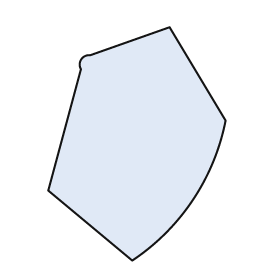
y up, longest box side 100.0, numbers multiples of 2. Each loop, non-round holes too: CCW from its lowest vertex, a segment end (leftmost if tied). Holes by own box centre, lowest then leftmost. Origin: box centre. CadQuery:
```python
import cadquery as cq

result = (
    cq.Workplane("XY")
    .moveTo(-2.0, -50.0)
    .threePointArc((24.0, -24.0), (38.0, 10.0))
    .lineTo(14.0, 50.0)
    .lineTo(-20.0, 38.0)
    .threePointArc((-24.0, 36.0), (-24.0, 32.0))
    .lineTo(-38.0, -20.0)
    .close()
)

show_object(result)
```